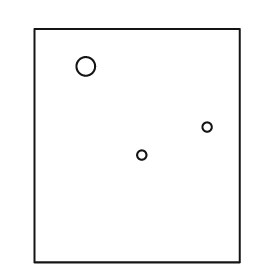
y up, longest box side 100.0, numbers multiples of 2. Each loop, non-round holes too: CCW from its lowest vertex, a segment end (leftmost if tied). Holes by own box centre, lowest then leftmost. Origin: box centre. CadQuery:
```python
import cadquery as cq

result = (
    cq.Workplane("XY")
    .moveTo(-44.0, -50.0)
    .lineTo(44.0, -50.0)
    .lineTo(44.0, 50.0)
    .lineTo(-44.0, 50.0)
    .close()
    .moveTo(2.0, -4.0)
    .circle(2.0)
    .moveTo(30.0, 8.0)
    .circle(2.0)
    .moveTo(-22.0, 34.0)
    .circle(4.0)
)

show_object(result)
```